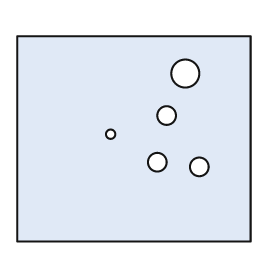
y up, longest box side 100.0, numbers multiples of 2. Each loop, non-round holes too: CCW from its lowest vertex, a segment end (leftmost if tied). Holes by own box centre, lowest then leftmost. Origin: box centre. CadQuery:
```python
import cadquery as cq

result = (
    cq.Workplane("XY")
    .moveTo(-50.0, -44.0)
    .lineTo(50.0, -44.0)
    .lineTo(50.0, 44.0)
    .lineTo(-50.0, 44.0)
    .close()
    .moveTo(28.0, -12.0)
    .circle(4.0)
    .moveTo(10.0, -10.0)
    .circle(4.0)
    .moveTo(-10.0, 2.0)
    .circle(2.0)
    .moveTo(14.0, 10.0)
    .circle(4.0)
    .moveTo(22.0, 28.0)
    .circle(6.0)
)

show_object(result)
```